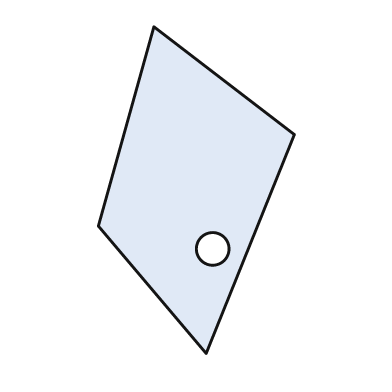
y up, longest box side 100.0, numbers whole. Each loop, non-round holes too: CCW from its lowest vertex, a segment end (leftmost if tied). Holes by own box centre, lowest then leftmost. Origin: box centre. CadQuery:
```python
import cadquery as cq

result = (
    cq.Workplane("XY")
    .moveTo(3.0, -50.0)
    .lineTo(30.0, 17.0)
    .lineTo(-13.0, 50.0)
    .lineTo(-30.0, -11.0)
    .close()
    .moveTo(5.0, -18.0)
    .circle(5.0)
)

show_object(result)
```